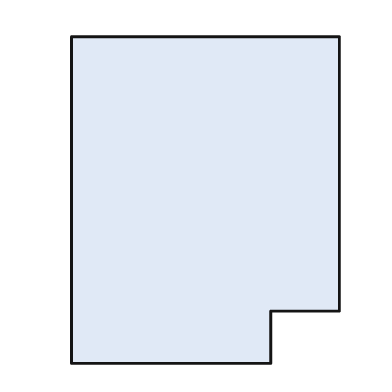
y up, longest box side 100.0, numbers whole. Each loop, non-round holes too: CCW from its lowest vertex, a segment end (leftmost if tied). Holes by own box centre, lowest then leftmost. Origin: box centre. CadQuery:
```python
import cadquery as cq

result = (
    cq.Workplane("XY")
    .moveTo(-41.0, -50.0)
    .lineTo(20.0, -50.0)
    .lineTo(20.0, -34.0)
    .lineTo(41.0, -34.0)
    .lineTo(41.0, 50.0)
    .lineTo(-41.0, 50.0)
    .close()
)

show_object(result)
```